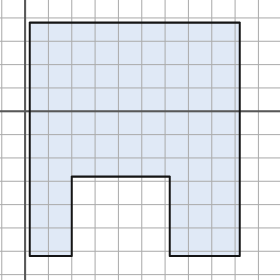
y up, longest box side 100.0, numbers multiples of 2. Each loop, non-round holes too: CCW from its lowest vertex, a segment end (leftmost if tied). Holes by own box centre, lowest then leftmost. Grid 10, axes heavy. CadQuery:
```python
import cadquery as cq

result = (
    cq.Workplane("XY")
    .moveTo(2.0, -62.0)
    .lineTo(20.0, -62.0)
    .lineTo(20.0, -28.0)
    .lineTo(62.0, -28.0)
    .lineTo(62.0, -62.0)
    .lineTo(92.0, -62.0)
    .lineTo(92.0, 38.0)
    .lineTo(2.0, 38.0)
    .close()
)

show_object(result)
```